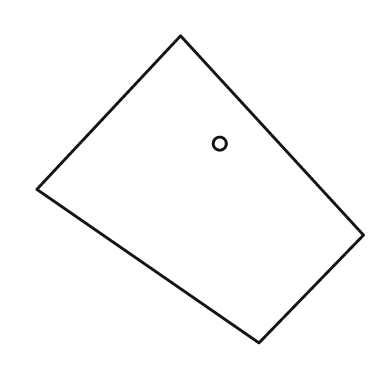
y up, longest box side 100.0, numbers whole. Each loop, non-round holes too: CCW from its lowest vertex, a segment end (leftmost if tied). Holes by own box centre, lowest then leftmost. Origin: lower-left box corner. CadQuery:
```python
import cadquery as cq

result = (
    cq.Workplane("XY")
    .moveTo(68.0, 0.0)
    .lineTo(100.0, 33.0)
    .lineTo(44.0, 94.0)
    .lineTo(0.0, 47.0)
    .close()
    .moveTo(56.0, 61.0)
    .circle(2.0)
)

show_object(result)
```